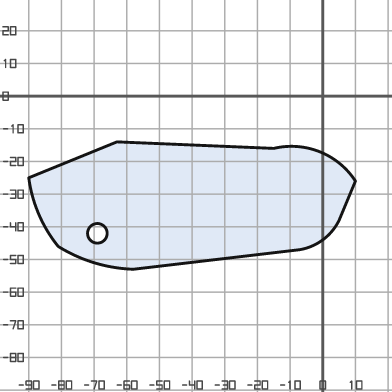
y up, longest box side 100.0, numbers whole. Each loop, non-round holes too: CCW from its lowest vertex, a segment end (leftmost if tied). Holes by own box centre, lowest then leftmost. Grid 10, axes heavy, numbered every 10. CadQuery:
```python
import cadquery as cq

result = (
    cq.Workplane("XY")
    .moveTo(-58.0, -53.0)
    .lineTo(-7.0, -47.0)
    .threePointArc((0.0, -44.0), (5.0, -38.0))
    .lineTo(10.0, -26.0)
    .threePointArc((-1.0, -17.0), (-15.0, -16.0))
    .lineTo(-63.0, -14.0)
    .lineTo(-90.0, -25.0)
    .threePointArc((-87.0, -36.0), (-81.0, -46.0))
    .threePointArc((-70.0, -51.0), (-58.0, -53.0))
    .close()
    .moveTo(-69.0, -42.0)
    .circle(3.0)
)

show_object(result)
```